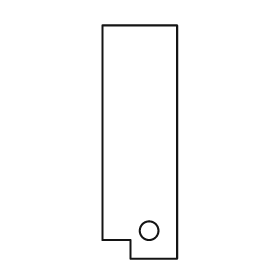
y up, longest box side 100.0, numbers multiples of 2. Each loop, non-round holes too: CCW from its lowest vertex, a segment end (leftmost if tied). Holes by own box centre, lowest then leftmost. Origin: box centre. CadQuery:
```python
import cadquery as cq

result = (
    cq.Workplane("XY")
    .moveTo(-4.0, -50.0)
    .lineTo(16.0, -50.0)
    .lineTo(16.0, 50.0)
    .lineTo(-16.0, 50.0)
    .lineTo(-16.0, -42.0)
    .lineTo(-4.0, -42.0)
    .close()
    .moveTo(4.0, -38.0)
    .circle(4.0)
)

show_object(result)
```